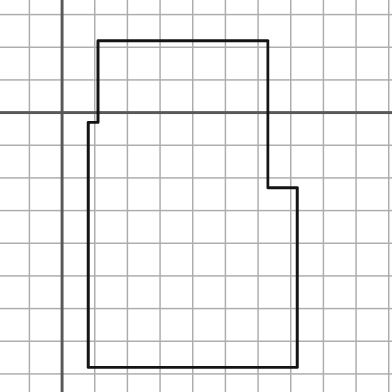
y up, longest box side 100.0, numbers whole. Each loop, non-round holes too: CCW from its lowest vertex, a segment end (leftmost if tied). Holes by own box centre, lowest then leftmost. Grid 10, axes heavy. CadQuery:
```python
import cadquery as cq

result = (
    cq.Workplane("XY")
    .moveTo(8.0, -78.0)
    .lineTo(72.0, -78.0)
    .lineTo(72.0, -23.0)
    .lineTo(63.0, -23.0)
    .lineTo(63.0, 22.0)
    .lineTo(11.0, 22.0)
    .lineTo(11.0, -3.0)
    .lineTo(8.0, -3.0)
    .close()
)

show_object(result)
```